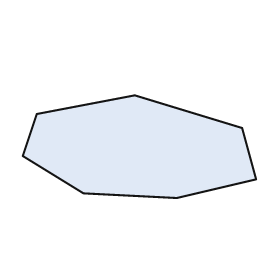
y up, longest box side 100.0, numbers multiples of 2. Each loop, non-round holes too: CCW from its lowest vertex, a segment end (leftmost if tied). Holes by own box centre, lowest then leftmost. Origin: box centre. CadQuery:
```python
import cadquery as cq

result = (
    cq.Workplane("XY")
    .moveTo(16.0, -22.0)
    .lineTo(50.0, -14.0)
    .lineTo(44.0, 8.0)
    .lineTo(-2.0, 22.0)
    .lineTo(-44.0, 14.0)
    .lineTo(-50.0, -4.0)
    .lineTo(-24.0, -20.0)
    .close()
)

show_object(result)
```